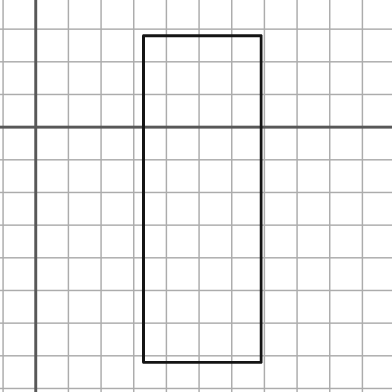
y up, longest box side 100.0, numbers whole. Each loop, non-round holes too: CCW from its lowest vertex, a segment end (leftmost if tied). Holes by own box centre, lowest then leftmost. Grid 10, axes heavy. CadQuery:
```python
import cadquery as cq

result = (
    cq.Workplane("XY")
    .moveTo(33.0, -72.0)
    .lineTo(69.0, -72.0)
    .lineTo(69.0, 28.0)
    .lineTo(33.0, 28.0)
    .close()
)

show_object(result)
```